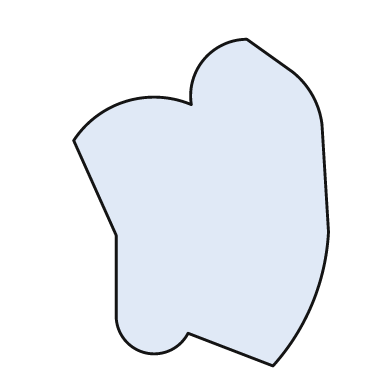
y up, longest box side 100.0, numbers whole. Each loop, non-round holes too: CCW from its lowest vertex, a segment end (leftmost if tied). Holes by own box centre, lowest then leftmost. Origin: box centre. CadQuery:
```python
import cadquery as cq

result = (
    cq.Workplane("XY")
    .moveTo(22.0, -50.0)
    .threePointArc((34.0, -31.0), (39.0, -9.0))
    .lineTo(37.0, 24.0)
    .threePointArc((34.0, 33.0), (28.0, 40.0))
    .lineTo(14.0, 50.0)
    .threePointArc((1.0, 44.0), (-3.0, 30.0))
    .threePointArc((-23.0, 31.0), (-39.0, 19.0))
    .lineTo(-26.0, -10.0)
    .lineTo(-26.0, -35.0)
    .threePointArc((-17.0, -46.0), (-4.0, -40.0))
    .close()
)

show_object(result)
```